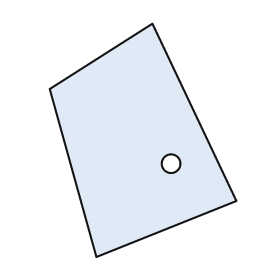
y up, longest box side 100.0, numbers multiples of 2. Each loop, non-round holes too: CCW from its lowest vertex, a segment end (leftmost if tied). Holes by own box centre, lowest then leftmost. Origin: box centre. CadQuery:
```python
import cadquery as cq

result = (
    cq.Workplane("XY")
    .moveTo(-20.0, -50.0)
    .lineTo(40.0, -26.0)
    .lineTo(4.0, 50.0)
    .lineTo(-40.0, 22.0)
    .close()
    .moveTo(12.0, -10.0)
    .circle(4.0)
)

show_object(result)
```